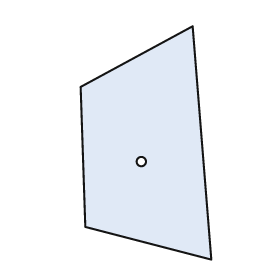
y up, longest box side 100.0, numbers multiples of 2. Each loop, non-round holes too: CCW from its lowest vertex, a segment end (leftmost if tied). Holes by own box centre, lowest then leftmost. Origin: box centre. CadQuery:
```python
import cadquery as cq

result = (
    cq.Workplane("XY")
    .moveTo(28.0, -50.0)
    .lineTo(20.0, 50.0)
    .lineTo(-28.0, 24.0)
    .lineTo(-26.0, -36.0)
    .close()
    .moveTo(-2.0, -8.0)
    .circle(2.0)
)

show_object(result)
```